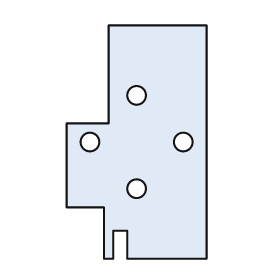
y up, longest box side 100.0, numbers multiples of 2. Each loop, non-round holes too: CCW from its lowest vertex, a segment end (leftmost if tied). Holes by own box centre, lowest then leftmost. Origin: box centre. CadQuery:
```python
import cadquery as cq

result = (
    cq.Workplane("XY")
    .moveTo(-14.0, -50.0)
    .lineTo(-10.0, -50.0)
    .lineTo(-10.0, -38.0)
    .lineTo(-4.0, -38.0)
    .lineTo(-4.0, -50.0)
    .lineTo(30.0, -50.0)
    .lineTo(30.0, 50.0)
    .lineTo(-12.0, 50.0)
    .lineTo(-12.0, 8.0)
    .lineTo(-30.0, 8.0)
    .lineTo(-30.0, -28.0)
    .lineTo(-14.0, -28.0)
    .close()
    .moveTo(0.0, -20.0)
    .circle(4.0)
    .moveTo(-20.0, 0.0)
    .circle(4.0)
    .moveTo(20.0, 0.0)
    .circle(4.0)
    .moveTo(0.0, 20.0)
    .circle(4.0)
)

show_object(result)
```